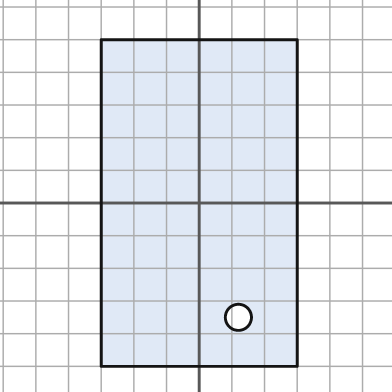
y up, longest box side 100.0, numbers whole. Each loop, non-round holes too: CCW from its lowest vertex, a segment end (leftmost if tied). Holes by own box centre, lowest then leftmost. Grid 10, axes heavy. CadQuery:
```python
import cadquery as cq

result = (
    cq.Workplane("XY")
    .moveTo(-30.0, -50.0)
    .lineTo(30.0, -50.0)
    .lineTo(30.0, 50.0)
    .lineTo(-30.0, 50.0)
    .close()
    .moveTo(12.0, -35.0)
    .circle(4.0)
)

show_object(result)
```